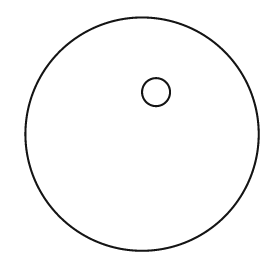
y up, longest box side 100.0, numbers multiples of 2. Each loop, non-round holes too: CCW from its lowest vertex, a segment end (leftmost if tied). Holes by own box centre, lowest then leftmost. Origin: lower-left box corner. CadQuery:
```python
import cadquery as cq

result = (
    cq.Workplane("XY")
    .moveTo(50.0, 50.0)
    .circle(50.0)
    .moveTo(56.0, 68.0)
    .circle(6.0)
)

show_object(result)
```